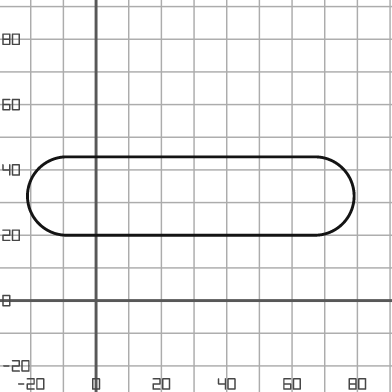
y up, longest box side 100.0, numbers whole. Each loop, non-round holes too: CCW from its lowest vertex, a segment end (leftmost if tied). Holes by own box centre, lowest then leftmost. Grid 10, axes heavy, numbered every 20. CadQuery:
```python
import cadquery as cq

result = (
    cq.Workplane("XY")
    .moveTo(-9.0, 20.0)
    .lineTo(67.0, 20.0)
    .threePointArc((79.0, 32.0), (67.0, 44.0))
    .lineTo(-9.0, 44.0)
    .threePointArc((-21.0, 32.0), (-9.0, 20.0))
    .close()
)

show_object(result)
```